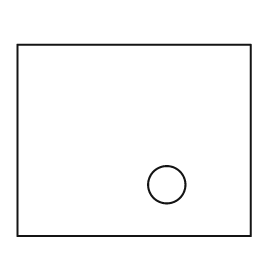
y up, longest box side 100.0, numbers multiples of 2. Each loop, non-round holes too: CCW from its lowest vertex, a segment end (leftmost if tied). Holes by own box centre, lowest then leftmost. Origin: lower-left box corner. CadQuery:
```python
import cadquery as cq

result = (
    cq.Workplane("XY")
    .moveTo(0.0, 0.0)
    .lineTo(100.0, 0.0)
    .lineTo(100.0, 82.0)
    .lineTo(0.0, 82.0)
    .close()
    .moveTo(64.0, 22.0)
    .circle(8.0)
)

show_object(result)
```